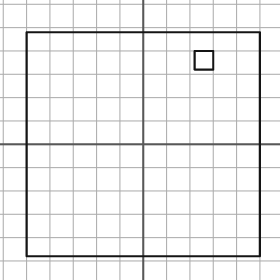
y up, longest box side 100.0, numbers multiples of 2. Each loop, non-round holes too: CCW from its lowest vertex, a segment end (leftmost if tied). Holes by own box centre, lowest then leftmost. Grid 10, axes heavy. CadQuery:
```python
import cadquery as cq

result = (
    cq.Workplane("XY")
    .moveTo(-50.0, -48.0)
    .lineTo(50.0, -48.0)
    .lineTo(50.0, 48.0)
    .lineTo(-50.0, 48.0)
    .close()
    .moveTo(22.0, 32.0)
    .lineTo(30.0, 32.0)
    .lineTo(30.0, 40.0)
    .lineTo(22.0, 40.0)
    .close()
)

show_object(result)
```